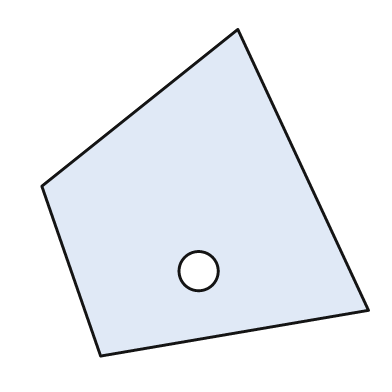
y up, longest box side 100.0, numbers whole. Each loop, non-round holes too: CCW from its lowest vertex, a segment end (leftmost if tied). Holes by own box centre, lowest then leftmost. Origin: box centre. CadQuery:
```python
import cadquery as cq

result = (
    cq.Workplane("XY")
    .moveTo(-32.0, -50.0)
    .lineTo(50.0, -36.0)
    .lineTo(10.0, 50.0)
    .lineTo(-50.0, 2.0)
    .close()
    .moveTo(-2.0, -24.0)
    .circle(6.0)
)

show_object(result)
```